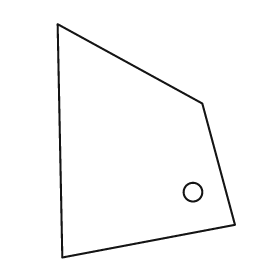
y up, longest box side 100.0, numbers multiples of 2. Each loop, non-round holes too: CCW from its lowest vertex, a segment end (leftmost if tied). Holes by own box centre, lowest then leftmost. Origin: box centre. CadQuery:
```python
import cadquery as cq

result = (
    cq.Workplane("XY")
    .moveTo(-36.0, -50.0)
    .lineTo(38.0, -36.0)
    .lineTo(24.0, 16.0)
    .lineTo(-38.0, 50.0)
    .close()
    .moveTo(20.0, -22.0)
    .circle(4.0)
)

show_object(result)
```